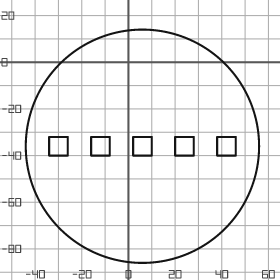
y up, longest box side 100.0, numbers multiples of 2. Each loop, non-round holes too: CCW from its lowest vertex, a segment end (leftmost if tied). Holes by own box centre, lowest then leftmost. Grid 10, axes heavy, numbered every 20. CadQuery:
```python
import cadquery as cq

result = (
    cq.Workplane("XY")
    .moveTo(6.0, -36.0)
    .circle(50.0)
    .moveTo(-34.0, -40.0)
    .lineTo(-26.0, -40.0)
    .lineTo(-26.0, -32.0)
    .lineTo(-34.0, -32.0)
    .close()
    .moveTo(-16.0, -40.0)
    .lineTo(-8.0, -40.0)
    .lineTo(-8.0, -32.0)
    .lineTo(-16.0, -32.0)
    .close()
    .moveTo(2.0, -40.0)
    .lineTo(10.0, -40.0)
    .lineTo(10.0, -32.0)
    .lineTo(2.0, -32.0)
    .close()
    .moveTo(20.0, -40.0)
    .lineTo(28.0, -40.0)
    .lineTo(28.0, -32.0)
    .lineTo(20.0, -32.0)
    .close()
    .moveTo(38.0, -40.0)
    .lineTo(46.0, -40.0)
    .lineTo(46.0, -32.0)
    .lineTo(38.0, -32.0)
    .close()
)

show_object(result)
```